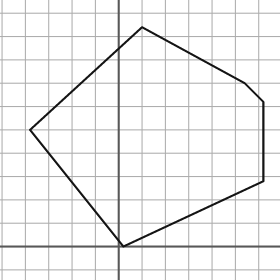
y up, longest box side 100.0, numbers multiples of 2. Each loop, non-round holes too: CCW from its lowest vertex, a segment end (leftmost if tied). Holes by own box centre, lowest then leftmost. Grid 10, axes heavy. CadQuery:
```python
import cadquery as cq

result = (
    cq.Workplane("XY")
    .moveTo(2.0, 0.0)
    .lineTo(62.0, 28.0)
    .lineTo(62.0, 62.0)
    .lineTo(54.0, 70.0)
    .lineTo(10.0, 94.0)
    .lineTo(-38.0, 50.0)
    .close()
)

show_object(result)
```